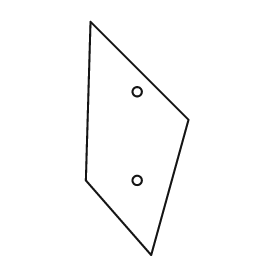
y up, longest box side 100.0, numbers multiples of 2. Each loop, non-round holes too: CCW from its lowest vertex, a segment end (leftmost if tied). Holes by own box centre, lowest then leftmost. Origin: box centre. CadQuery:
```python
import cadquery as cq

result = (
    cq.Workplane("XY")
    .moveTo(6.0, -50.0)
    .lineTo(22.0, 8.0)
    .lineTo(-20.0, 50.0)
    .lineTo(-22.0, -18.0)
    .close()
    .moveTo(0.0, -18.0)
    .circle(2.0)
    .moveTo(0.0, 20.0)
    .circle(2.0)
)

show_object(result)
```